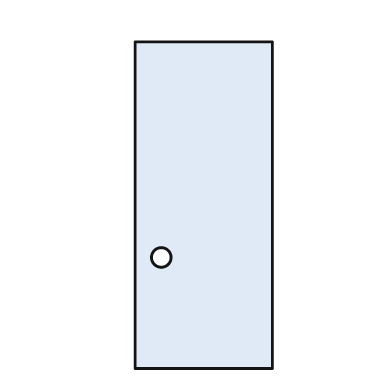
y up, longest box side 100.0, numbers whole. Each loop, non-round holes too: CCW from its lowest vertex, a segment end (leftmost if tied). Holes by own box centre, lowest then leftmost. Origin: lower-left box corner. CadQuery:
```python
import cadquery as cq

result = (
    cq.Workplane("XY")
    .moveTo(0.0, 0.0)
    .lineTo(42.0, 0.0)
    .lineTo(42.0, 100.0)
    .lineTo(0.0, 100.0)
    .close()
    .moveTo(8.0, 34.0)
    .circle(3.0)
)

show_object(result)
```